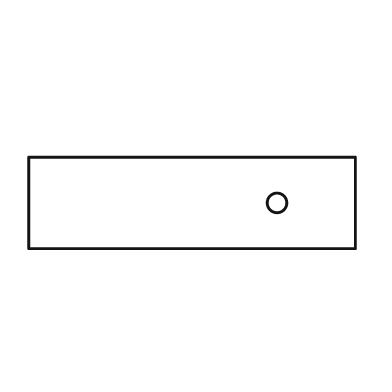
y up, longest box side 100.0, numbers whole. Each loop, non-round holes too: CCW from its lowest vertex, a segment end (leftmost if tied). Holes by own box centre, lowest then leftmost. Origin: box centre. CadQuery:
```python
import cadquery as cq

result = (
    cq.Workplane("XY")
    .moveTo(-50.0, -14.0)
    .lineTo(50.0, -14.0)
    .lineTo(50.0, 14.0)
    .lineTo(-50.0, 14.0)
    .close()
    .moveTo(26.0, 0.0)
    .circle(3.0)
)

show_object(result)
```